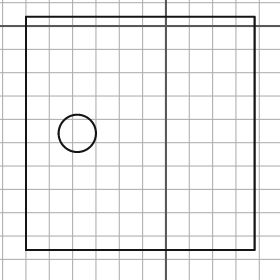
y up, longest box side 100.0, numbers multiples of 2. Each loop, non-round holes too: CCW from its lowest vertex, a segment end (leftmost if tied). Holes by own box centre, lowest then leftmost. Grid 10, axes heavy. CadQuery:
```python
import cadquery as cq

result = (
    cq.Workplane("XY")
    .moveTo(-60.0, -96.0)
    .lineTo(38.0, -96.0)
    .lineTo(38.0, 4.0)
    .lineTo(-60.0, 4.0)
    .close()
    .moveTo(-38.0, -46.0)
    .circle(8.0)
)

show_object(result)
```